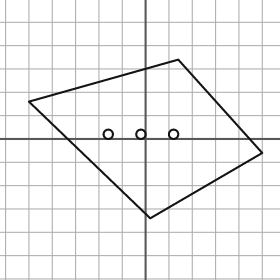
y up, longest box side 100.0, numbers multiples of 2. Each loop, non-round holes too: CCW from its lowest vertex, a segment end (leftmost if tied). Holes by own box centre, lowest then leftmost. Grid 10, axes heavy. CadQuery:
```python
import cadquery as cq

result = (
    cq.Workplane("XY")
    .moveTo(2.0, -34.0)
    .lineTo(50.0, -6.0)
    .lineTo(14.0, 34.0)
    .lineTo(-50.0, 16.0)
    .close()
    .moveTo(-16.0, 2.0)
    .circle(2.0)
    .moveTo(-2.0, 2.0)
    .circle(2.0)
    .moveTo(12.0, 2.0)
    .circle(2.0)
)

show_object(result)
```